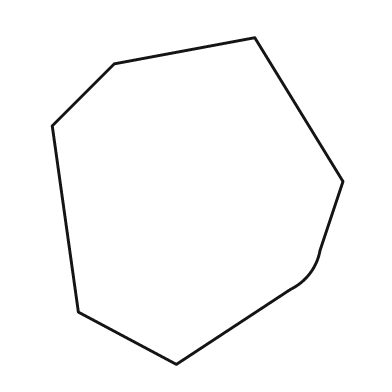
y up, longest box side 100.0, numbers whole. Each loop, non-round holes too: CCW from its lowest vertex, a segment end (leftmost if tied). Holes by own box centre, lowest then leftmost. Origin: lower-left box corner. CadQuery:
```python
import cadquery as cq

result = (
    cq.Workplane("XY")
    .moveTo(38.0, 0.0)
    .lineTo(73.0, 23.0)
    .threePointArc((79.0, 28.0), (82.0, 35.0))
    .lineTo(89.0, 56.0)
    .lineTo(62.0, 100.0)
    .lineTo(19.0, 92.0)
    .lineTo(0.0, 73.0)
    .lineTo(8.0, 16.0)
    .close()
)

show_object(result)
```